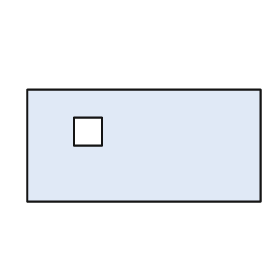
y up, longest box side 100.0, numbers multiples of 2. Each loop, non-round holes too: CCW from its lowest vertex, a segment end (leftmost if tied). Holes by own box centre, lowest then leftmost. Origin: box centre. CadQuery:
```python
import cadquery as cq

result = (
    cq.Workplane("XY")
    .moveTo(-50.0, -24.0)
    .lineTo(50.0, -24.0)
    .lineTo(50.0, 24.0)
    .lineTo(-50.0, 24.0)
    .close()
    .moveTo(-30.0, 0.0)
    .lineTo(-18.0, 0.0)
    .lineTo(-18.0, 12.0)
    .lineTo(-30.0, 12.0)
    .close()
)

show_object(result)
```